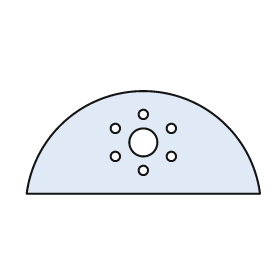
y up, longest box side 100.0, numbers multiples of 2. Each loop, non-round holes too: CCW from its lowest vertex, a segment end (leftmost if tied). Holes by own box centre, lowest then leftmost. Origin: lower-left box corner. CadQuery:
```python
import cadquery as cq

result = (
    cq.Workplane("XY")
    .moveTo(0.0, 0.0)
    .lineTo(100.0, 0.0)
    .threePointArc((50.0, 44.0), (0.0, 0.0))
    .close()
    .moveTo(50.0, 10.0)
    .circle(2.0)
    .moveTo(38.0, 16.0)
    .circle(2.0)
    .moveTo(62.0, 16.0)
    .circle(2.0)
    .moveTo(50.0, 22.0)
    .circle(6.0)
    .moveTo(38.0, 28.0)
    .circle(2.0)
    .moveTo(62.0, 28.0)
    .circle(2.0)
    .moveTo(50.0, 34.0)
    .circle(2.0)
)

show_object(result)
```